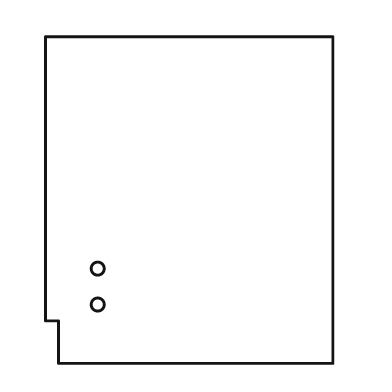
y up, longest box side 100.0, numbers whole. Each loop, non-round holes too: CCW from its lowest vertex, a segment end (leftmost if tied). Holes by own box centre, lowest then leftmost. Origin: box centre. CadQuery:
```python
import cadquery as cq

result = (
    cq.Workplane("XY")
    .moveTo(-40.0, -50.0)
    .lineTo(44.0, -50.0)
    .lineTo(44.0, 50.0)
    .lineTo(-44.0, 50.0)
    .lineTo(-44.0, -37.0)
    .lineTo(-40.0, -37.0)
    .close()
    .moveTo(-28.0, -32.0)
    .circle(2.0)
    .moveTo(-28.0, -21.0)
    .circle(2.0)
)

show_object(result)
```